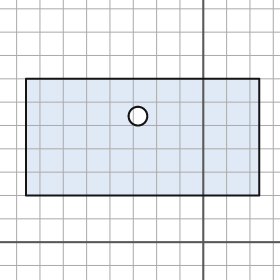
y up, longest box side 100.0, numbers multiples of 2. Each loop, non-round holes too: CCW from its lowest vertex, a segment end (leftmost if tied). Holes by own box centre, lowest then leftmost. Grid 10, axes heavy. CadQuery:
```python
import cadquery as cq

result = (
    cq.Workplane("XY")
    .moveTo(-76.0, 20.0)
    .lineTo(24.0, 20.0)
    .lineTo(24.0, 70.0)
    .lineTo(-76.0, 70.0)
    .close()
    .moveTo(-28.0, 54.0)
    .circle(4.0)
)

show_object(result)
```